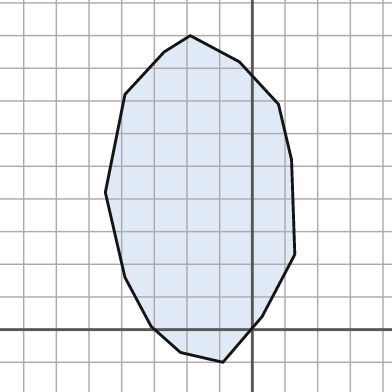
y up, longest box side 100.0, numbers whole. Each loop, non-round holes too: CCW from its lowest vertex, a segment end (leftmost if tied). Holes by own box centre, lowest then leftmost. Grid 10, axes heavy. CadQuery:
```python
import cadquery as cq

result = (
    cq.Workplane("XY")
    .moveTo(-9.0, -10.0)
    .lineTo(3.0, 4.0)
    .lineTo(13.0, 23.0)
    .lineTo(12.0, 52.0)
    .lineTo(8.0, 69.0)
    .lineTo(-4.0, 82.0)
    .lineTo(-19.0, 90.0)
    .lineTo(-27.0, 85.0)
    .lineTo(-39.0, 72.0)
    .lineTo(-45.0, 42.0)
    .lineTo(-39.0, 16.0)
    .lineTo(-31.0, 1.0)
    .lineTo(-22.0, -7.0)
    .close()
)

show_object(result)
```